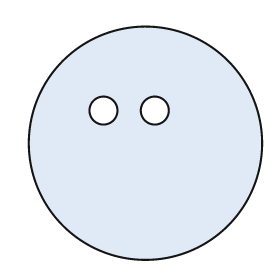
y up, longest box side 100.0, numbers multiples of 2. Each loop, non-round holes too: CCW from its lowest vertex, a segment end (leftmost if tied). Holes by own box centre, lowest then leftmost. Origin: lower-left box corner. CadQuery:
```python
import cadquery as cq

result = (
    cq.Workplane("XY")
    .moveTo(50.0, 50.0)
    .circle(50.0)
    .moveTo(32.0, 64.0)
    .circle(6.0)
    .moveTo(54.0, 64.0)
    .circle(6.0)
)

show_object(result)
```